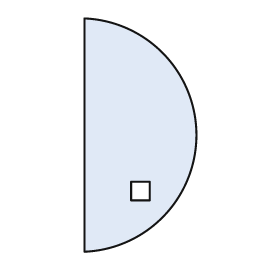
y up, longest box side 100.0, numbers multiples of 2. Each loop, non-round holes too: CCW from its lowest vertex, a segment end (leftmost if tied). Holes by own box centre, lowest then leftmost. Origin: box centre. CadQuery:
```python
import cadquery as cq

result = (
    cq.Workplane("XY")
    .moveTo(-24.0, -50.0)
    .threePointArc((24.0, 0.0), (-24.0, 50.0))
    .close()
    .moveTo(-4.0, -28.0)
    .lineTo(4.0, -28.0)
    .lineTo(4.0, -20.0)
    .lineTo(-4.0, -20.0)
    .close()
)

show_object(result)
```